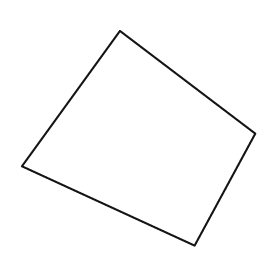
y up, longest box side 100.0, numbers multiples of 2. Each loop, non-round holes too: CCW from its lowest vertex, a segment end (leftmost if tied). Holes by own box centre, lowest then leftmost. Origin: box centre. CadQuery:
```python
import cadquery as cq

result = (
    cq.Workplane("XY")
    .moveTo(24.0, -46.0)
    .lineTo(50.0, 2.0)
    .lineTo(-8.0, 46.0)
    .lineTo(-50.0, -12.0)
    .close()
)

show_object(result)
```